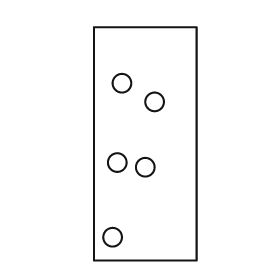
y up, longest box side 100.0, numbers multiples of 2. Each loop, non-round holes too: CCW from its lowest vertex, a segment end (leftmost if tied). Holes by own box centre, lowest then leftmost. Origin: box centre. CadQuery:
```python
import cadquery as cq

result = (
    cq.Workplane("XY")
    .moveTo(-22.0, -50.0)
    .lineTo(22.0, -50.0)
    .lineTo(22.0, 50.0)
    .lineTo(-22.0, 50.0)
    .close()
    .moveTo(-14.0, -40.0)
    .circle(4.0)
    .moveTo(0.0, -10.0)
    .circle(4.0)
    .moveTo(-12.0, -8.0)
    .circle(4.0)
    .moveTo(4.0, 18.0)
    .circle(4.0)
    .moveTo(-10.0, 26.0)
    .circle(4.0)
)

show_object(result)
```